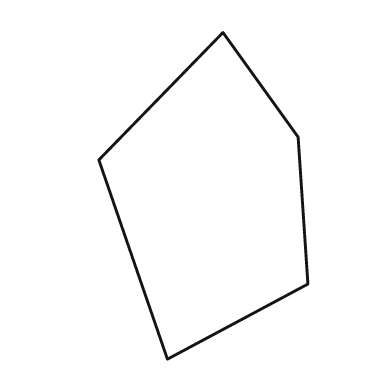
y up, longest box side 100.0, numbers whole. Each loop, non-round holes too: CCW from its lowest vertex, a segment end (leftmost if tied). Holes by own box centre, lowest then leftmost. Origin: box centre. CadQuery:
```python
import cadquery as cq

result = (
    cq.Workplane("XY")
    .moveTo(-11.0, -50.0)
    .lineTo(32.0, -27.0)
    .lineTo(29.0, 18.0)
    .lineTo(6.0, 50.0)
    .lineTo(-32.0, 11.0)
    .close()
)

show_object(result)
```